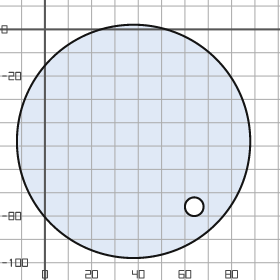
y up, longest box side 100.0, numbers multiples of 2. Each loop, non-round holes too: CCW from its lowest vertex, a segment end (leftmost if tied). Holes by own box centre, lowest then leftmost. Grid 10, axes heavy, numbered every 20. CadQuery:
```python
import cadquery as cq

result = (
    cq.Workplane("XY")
    .moveTo(38.0, -48.0)
    .circle(50.0)
    .moveTo(64.0, -76.0)
    .circle(4.0)
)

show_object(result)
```